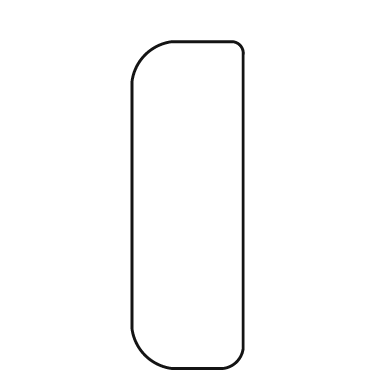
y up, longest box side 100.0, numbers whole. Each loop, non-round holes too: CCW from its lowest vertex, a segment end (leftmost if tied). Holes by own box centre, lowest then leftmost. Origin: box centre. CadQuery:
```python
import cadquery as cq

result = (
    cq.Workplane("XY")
    .moveTo(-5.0, -50.0)
    .lineTo(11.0, -50.0)
    .threePointArc((15.0, -48.0), (17.0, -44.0))
    .lineTo(17.0, 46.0)
    .threePointArc((16.0, 49.0), (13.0, 50.0))
    .lineTo(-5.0, 50.0)
    .threePointArc((-13.0, 46.0), (-17.0, 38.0))
    .lineTo(-17.0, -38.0)
    .threePointArc((-13.0, -46.0), (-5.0, -50.0))
    .close()
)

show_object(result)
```